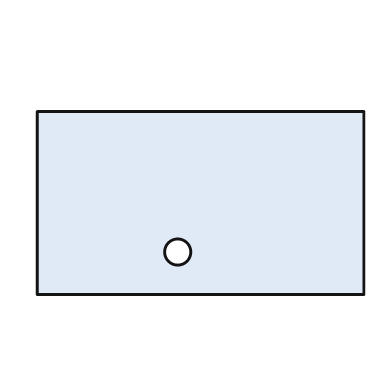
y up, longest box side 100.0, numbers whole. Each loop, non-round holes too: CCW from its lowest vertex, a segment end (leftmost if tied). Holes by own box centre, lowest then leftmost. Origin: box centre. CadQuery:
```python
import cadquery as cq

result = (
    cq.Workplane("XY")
    .moveTo(-50.0, -28.0)
    .lineTo(50.0, -28.0)
    .lineTo(50.0, 28.0)
    .lineTo(-50.0, 28.0)
    .close()
    .moveTo(-7.0, -15.0)
    .circle(4.0)
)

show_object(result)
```